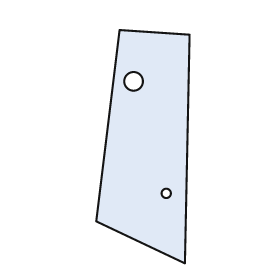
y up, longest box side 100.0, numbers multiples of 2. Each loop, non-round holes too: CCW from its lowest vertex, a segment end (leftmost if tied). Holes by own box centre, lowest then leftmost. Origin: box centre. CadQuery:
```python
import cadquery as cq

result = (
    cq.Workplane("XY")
    .moveTo(18.0, -50.0)
    .lineTo(20.0, 48.0)
    .lineTo(-10.0, 50.0)
    .lineTo(-20.0, -32.0)
    .close()
    .moveTo(10.0, -20.0)
    .circle(2.0)
    .moveTo(-4.0, 28.0)
    .circle(4.0)
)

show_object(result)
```